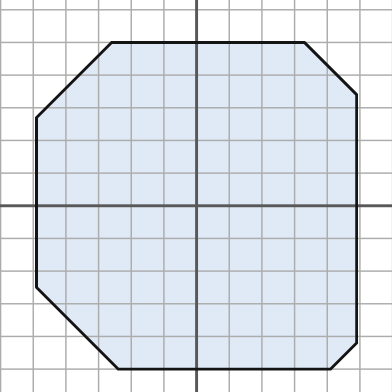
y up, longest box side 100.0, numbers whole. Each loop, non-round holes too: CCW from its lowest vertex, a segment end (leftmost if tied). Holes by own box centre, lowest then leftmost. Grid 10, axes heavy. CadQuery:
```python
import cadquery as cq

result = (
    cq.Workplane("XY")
    .moveTo(-24.0, -50.0)
    .lineTo(41.0, -50.0)
    .lineTo(49.0, -42.0)
    .lineTo(49.0, 34.0)
    .lineTo(33.0, 50.0)
    .lineTo(-26.0, 50.0)
    .lineTo(-49.0, 27.0)
    .lineTo(-49.0, -25.0)
    .close()
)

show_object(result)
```